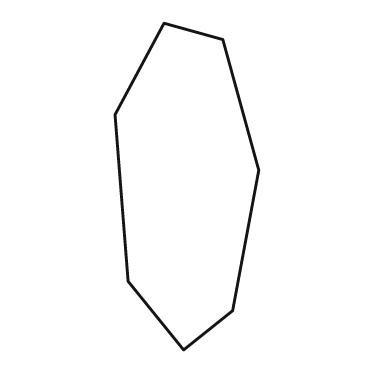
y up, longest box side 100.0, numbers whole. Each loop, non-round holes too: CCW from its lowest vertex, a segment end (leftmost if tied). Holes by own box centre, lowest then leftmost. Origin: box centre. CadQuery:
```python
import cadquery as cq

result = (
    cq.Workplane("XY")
    .moveTo(-1.0, -50.0)
    .lineTo(14.0, -38.0)
    .lineTo(22.0, 5.0)
    .lineTo(11.0, 45.0)
    .lineTo(-7.0, 50.0)
    .lineTo(-22.0, 22.0)
    .lineTo(-18.0, -29.0)
    .close()
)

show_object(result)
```